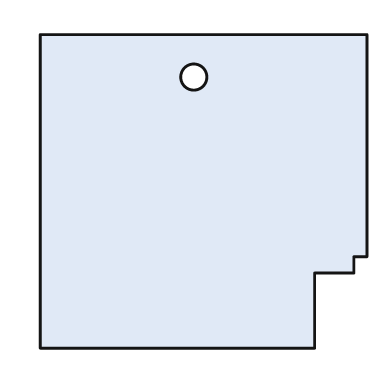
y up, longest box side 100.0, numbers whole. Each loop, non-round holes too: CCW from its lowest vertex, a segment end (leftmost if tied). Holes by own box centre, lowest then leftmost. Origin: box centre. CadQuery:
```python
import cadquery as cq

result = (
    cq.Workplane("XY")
    .moveTo(-50.0, -48.0)
    .lineTo(34.0, -48.0)
    .lineTo(34.0, -25.0)
    .lineTo(46.0, -25.0)
    .lineTo(46.0, -20.0)
    .lineTo(50.0, -20.0)
    .lineTo(50.0, 48.0)
    .lineTo(-50.0, 48.0)
    .close()
    .moveTo(-3.0, 35.0)
    .circle(4.0)
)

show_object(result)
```